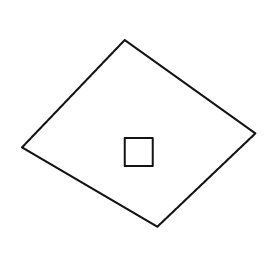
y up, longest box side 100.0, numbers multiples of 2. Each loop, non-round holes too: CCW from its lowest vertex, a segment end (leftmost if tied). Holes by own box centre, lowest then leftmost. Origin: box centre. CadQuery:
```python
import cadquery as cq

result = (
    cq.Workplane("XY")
    .moveTo(8.0, -40.0)
    .lineTo(50.0, 0.0)
    .lineTo(-6.0, 40.0)
    .lineTo(-50.0, -6.0)
    .close()
    .moveTo(-6.0, -14.0)
    .lineTo(6.0, -14.0)
    .lineTo(6.0, -2.0)
    .lineTo(-6.0, -2.0)
    .close()
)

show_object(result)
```